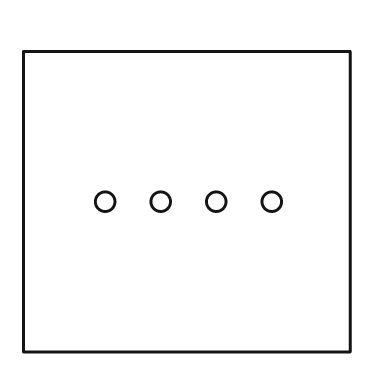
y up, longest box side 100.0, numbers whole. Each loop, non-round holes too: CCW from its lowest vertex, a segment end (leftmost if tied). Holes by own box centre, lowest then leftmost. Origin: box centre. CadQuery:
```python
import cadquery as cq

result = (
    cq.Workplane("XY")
    .moveTo(-50.0, -46.0)
    .lineTo(50.0, -46.0)
    .lineTo(50.0, 46.0)
    .lineTo(-50.0, 46.0)
    .close()
    .moveTo(-25.0, 0.0)
    .circle(3.0)
    .moveTo(-8.0, 0.0)
    .circle(3.0)
    .moveTo(9.0, 0.0)
    .circle(3.0)
    .moveTo(26.0, 0.0)
    .circle(3.0)
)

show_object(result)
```